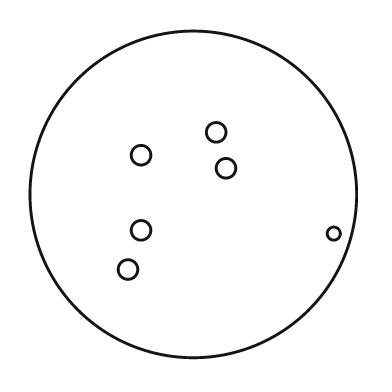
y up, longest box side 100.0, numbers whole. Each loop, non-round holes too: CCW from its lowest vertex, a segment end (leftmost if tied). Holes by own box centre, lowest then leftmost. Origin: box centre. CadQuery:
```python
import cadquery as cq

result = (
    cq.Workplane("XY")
    .moveTo(0.0, 0.0)
    .circle(50.0)
    .moveTo(-20.0, -23.0)
    .circle(3.0)
    .moveTo(43.0, -12.0)
    .circle(2.0)
    .moveTo(-16.0, -11.0)
    .circle(3.0)
    .moveTo(10.0, 8.0)
    .circle(3.0)
    .moveTo(-16.0, 12.0)
    .circle(3.0)
    .moveTo(7.0, 19.0)
    .circle(3.0)
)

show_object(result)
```